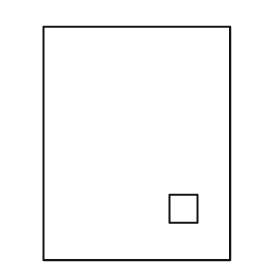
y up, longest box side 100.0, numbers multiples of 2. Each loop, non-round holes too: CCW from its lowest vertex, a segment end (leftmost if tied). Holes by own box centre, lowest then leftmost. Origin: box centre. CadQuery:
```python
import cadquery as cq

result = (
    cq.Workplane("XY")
    .moveTo(-40.0, -50.0)
    .lineTo(40.0, -50.0)
    .lineTo(40.0, 50.0)
    .lineTo(-40.0, 50.0)
    .close()
    .moveTo(14.0, -34.0)
    .lineTo(26.0, -34.0)
    .lineTo(26.0, -22.0)
    .lineTo(14.0, -22.0)
    .close()
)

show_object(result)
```